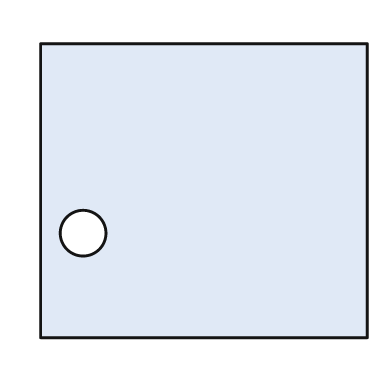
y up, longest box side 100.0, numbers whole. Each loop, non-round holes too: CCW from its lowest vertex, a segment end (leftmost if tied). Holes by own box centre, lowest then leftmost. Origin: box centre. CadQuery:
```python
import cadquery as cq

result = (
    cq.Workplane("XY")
    .moveTo(-50.0, -45.0)
    .lineTo(50.0, -45.0)
    .lineTo(50.0, 45.0)
    .lineTo(-50.0, 45.0)
    .close()
    .moveTo(-37.0, -13.0)
    .circle(7.0)
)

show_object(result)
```